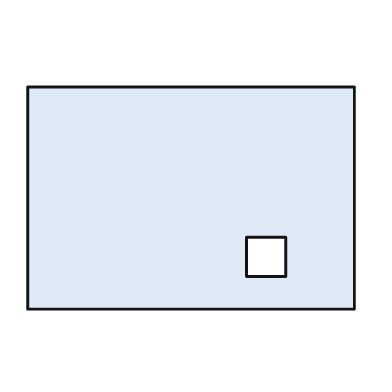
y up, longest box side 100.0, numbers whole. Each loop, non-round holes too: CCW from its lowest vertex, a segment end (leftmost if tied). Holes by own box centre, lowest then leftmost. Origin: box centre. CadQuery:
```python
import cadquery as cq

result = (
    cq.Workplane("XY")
    .moveTo(-50.0, -34.0)
    .lineTo(50.0, -34.0)
    .lineTo(50.0, 34.0)
    .lineTo(-50.0, 34.0)
    .close()
    .moveTo(17.0, -24.0)
    .lineTo(29.0, -24.0)
    .lineTo(29.0, -12.0)
    .lineTo(17.0, -12.0)
    .close()
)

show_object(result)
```